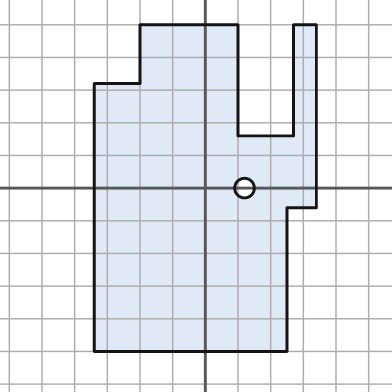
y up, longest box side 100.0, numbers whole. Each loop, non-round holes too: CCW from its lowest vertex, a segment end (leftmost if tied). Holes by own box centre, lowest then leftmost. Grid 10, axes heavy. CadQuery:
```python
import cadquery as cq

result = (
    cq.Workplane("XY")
    .moveTo(-34.0, -50.0)
    .lineTo(25.0, -50.0)
    .lineTo(25.0, -6.0)
    .lineTo(34.0, -6.0)
    .lineTo(34.0, 50.0)
    .lineTo(27.0, 50.0)
    .lineTo(27.0, 16.0)
    .lineTo(10.0, 16.0)
    .lineTo(10.0, 50.0)
    .lineTo(-20.0, 50.0)
    .lineTo(-20.0, 32.0)
    .lineTo(-34.0, 32.0)
    .close()
    .moveTo(12.0, 0.0)
    .circle(3.0)
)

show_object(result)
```